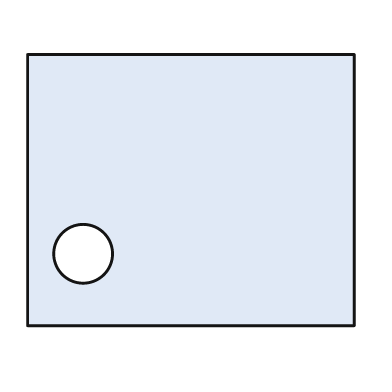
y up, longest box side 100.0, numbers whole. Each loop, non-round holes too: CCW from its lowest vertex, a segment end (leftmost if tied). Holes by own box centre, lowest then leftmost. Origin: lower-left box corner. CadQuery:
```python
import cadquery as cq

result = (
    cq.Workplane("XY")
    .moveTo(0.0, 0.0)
    .lineTo(100.0, 0.0)
    .lineTo(100.0, 83.0)
    .lineTo(0.0, 83.0)
    .close()
    .moveTo(17.0, 22.0)
    .circle(9.0)
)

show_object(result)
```